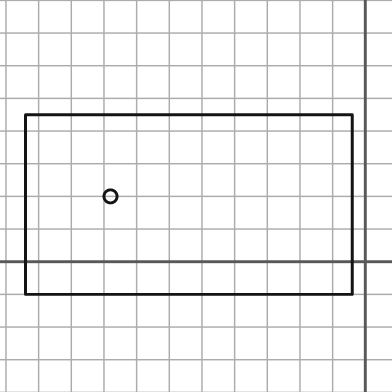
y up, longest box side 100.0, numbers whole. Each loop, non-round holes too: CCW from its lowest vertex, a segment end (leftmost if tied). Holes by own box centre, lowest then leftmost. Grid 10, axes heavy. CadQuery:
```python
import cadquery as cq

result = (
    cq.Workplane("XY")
    .moveTo(-104.0, -10.0)
    .lineTo(-4.0, -10.0)
    .lineTo(-4.0, 45.0)
    .lineTo(-104.0, 45.0)
    .close()
    .moveTo(-78.0, 20.0)
    .circle(2.0)
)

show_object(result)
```